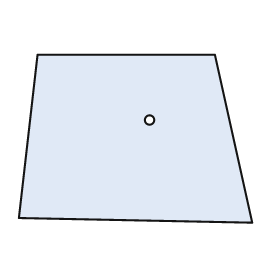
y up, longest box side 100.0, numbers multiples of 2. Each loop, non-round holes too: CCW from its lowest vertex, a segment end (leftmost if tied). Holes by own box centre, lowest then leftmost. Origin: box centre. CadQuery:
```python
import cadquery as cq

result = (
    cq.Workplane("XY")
    .moveTo(50.0, -36.0)
    .lineTo(34.0, 36.0)
    .lineTo(-42.0, 36.0)
    .lineTo(-50.0, -34.0)
    .close()
    .moveTo(6.0, 8.0)
    .circle(2.0)
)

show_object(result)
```